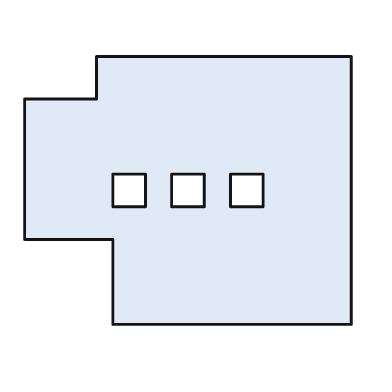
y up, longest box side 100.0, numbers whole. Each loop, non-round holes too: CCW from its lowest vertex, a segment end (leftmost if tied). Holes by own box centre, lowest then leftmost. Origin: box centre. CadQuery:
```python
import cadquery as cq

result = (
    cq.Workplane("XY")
    .moveTo(-23.0, -41.0)
    .lineTo(50.0, -41.0)
    .lineTo(50.0, 41.0)
    .lineTo(-28.0, 41.0)
    .lineTo(-28.0, 28.0)
    .lineTo(-50.0, 28.0)
    .lineTo(-50.0, -15.0)
    .lineTo(-23.0, -15.0)
    .close()
    .moveTo(-23.0, -5.0)
    .lineTo(-13.0, -5.0)
    .lineTo(-13.0, 5.0)
    .lineTo(-23.0, 5.0)
    .close()
    .moveTo(-5.0, -5.0)
    .lineTo(5.0, -5.0)
    .lineTo(5.0, 5.0)
    .lineTo(-5.0, 5.0)
    .close()
    .moveTo(13.0, -5.0)
    .lineTo(23.0, -5.0)
    .lineTo(23.0, 5.0)
    .lineTo(13.0, 5.0)
    .close()
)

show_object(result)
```